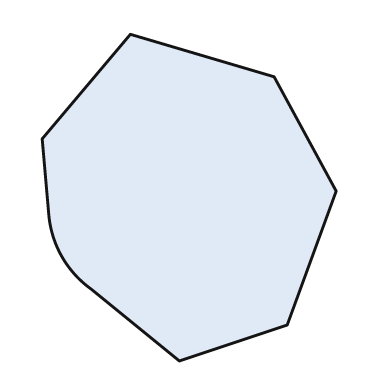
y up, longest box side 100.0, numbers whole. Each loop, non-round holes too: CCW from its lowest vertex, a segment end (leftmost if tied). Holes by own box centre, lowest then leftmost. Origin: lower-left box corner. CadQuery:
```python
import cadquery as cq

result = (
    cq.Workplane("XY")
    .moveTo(42.0, 0.0)
    .lineTo(75.0, 11.0)
    .lineTo(90.0, 52.0)
    .lineTo(71.0, 87.0)
    .lineTo(27.0, 100.0)
    .lineTo(0.0, 68.0)
    .lineTo(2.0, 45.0)
    .threePointArc((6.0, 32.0), (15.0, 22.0))
    .close()
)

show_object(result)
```